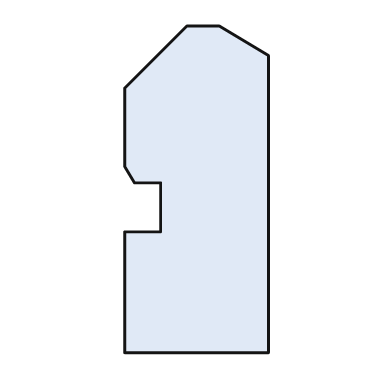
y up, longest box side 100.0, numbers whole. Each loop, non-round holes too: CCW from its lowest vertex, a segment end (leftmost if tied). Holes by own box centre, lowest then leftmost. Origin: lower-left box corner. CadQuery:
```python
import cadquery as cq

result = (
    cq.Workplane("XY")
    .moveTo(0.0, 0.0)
    .lineTo(44.0, 0.0)
    .lineTo(44.0, 91.0)
    .lineTo(29.0, 100.0)
    .lineTo(19.0, 100.0)
    .lineTo(0.0, 81.0)
    .lineTo(0.0, 57.0)
    .lineTo(3.0, 52.0)
    .lineTo(11.0, 52.0)
    .lineTo(11.0, 37.0)
    .lineTo(0.0, 37.0)
    .close()
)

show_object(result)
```